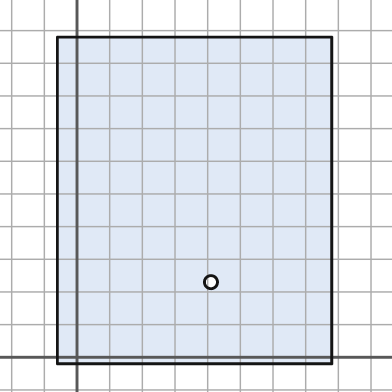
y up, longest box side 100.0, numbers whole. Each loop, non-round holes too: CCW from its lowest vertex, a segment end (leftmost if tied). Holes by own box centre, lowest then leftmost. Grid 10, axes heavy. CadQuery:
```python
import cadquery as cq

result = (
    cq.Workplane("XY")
    .moveTo(-6.0, -2.0)
    .lineTo(78.0, -2.0)
    .lineTo(78.0, 98.0)
    .lineTo(-6.0, 98.0)
    .close()
    .moveTo(41.0, 23.0)
    .circle(2.0)
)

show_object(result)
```